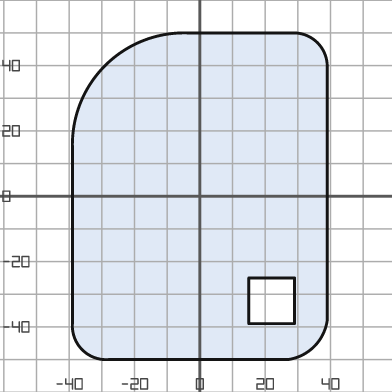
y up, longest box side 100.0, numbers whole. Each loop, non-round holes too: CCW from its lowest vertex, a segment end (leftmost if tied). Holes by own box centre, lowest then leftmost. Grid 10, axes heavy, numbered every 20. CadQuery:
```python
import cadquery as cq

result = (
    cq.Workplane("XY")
    .moveTo(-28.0, -50.0)
    .lineTo(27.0, -50.0)
    .threePointArc((35.0, -46.0), (39.0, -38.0))
    .lineTo(39.0, 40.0)
    .threePointArc((36.0, 47.0), (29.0, 50.0))
    .lineTo(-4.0, 50.0)
    .threePointArc((-29.0, 40.0), (-39.0, 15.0))
    .lineTo(-39.0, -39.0)
    .threePointArc((-36.0, -47.0), (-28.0, -50.0))
    .close()
    .moveTo(15.0, -39.0)
    .lineTo(29.0, -39.0)
    .lineTo(29.0, -25.0)
    .lineTo(15.0, -25.0)
    .close()
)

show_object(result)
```